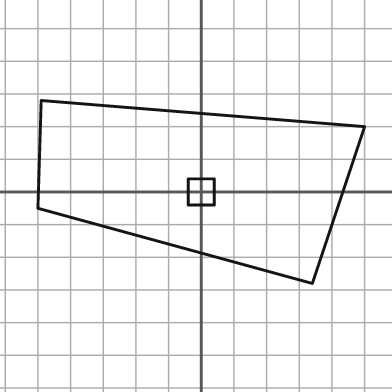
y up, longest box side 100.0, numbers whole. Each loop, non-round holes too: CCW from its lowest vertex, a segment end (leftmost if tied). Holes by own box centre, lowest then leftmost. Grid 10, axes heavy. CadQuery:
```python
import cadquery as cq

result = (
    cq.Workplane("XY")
    .moveTo(34.0, -28.0)
    .lineTo(50.0, 20.0)
    .lineTo(-49.0, 28.0)
    .lineTo(-50.0, -5.0)
    .close()
    .moveTo(-4.0, -4.0)
    .lineTo(4.0, -4.0)
    .lineTo(4.0, 4.0)
    .lineTo(-4.0, 4.0)
    .close()
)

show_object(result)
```